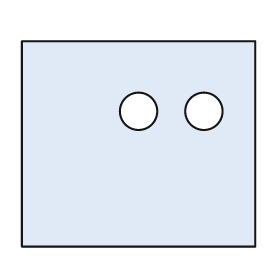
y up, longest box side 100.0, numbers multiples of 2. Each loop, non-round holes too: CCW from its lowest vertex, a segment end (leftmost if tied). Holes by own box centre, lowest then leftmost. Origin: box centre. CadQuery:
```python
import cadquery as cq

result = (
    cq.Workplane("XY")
    .moveTo(-50.0, -44.0)
    .lineTo(50.0, -44.0)
    .lineTo(50.0, 44.0)
    .lineTo(-50.0, 44.0)
    .close()
    .moveTo(0.0, 14.0)
    .circle(8.0)
    .moveTo(28.0, 14.0)
    .circle(8.0)
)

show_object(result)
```